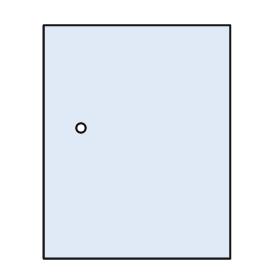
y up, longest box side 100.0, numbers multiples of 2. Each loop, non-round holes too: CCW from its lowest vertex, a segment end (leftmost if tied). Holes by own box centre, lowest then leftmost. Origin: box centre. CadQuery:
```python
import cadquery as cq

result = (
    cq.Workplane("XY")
    .moveTo(-40.0, -50.0)
    .lineTo(40.0, -50.0)
    .lineTo(40.0, 50.0)
    .lineTo(-40.0, 50.0)
    .close()
    .moveTo(-24.0, 6.0)
    .circle(2.0)
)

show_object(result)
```